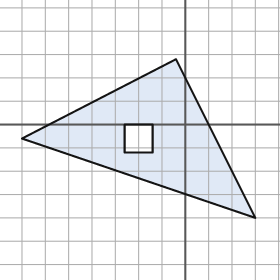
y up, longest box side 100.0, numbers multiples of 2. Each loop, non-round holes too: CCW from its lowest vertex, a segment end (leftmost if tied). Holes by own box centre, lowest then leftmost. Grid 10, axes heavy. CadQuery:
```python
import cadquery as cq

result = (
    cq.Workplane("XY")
    .moveTo(30.0, -40.0)
    .lineTo(-4.0, 28.0)
    .lineTo(-70.0, -6.0)
    .close()
    .moveTo(-26.0, -12.0)
    .lineTo(-14.0, -12.0)
    .lineTo(-14.0, 0.0)
    .lineTo(-26.0, 0.0)
    .close()
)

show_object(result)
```